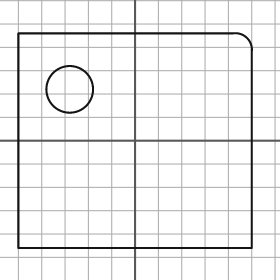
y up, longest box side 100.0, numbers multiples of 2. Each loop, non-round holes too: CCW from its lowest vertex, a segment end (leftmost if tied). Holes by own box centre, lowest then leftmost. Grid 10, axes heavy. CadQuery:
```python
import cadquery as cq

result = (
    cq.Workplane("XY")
    .moveTo(-50.0, -46.0)
    .lineTo(50.0, -46.0)
    .lineTo(50.0, 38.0)
    .threePointArc((48.0, 44.0), (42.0, 46.0))
    .lineTo(-50.0, 46.0)
    .close()
    .moveTo(-28.0, 22.0)
    .circle(10.0)
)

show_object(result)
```